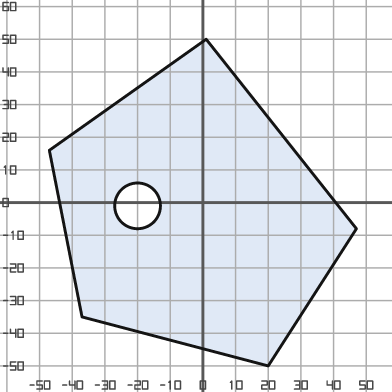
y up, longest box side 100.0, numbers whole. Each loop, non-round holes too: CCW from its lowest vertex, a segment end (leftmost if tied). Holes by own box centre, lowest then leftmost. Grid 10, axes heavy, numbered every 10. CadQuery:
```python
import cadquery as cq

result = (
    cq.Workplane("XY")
    .moveTo(20.0, -50.0)
    .lineTo(47.0, -8.0)
    .lineTo(1.0, 50.0)
    .lineTo(-47.0, 16.0)
    .lineTo(-37.0, -35.0)
    .close()
    .moveTo(-20.0, -1.0)
    .circle(7.0)
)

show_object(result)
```